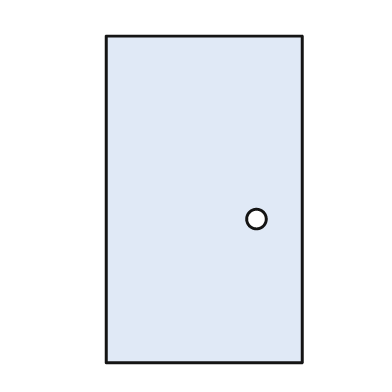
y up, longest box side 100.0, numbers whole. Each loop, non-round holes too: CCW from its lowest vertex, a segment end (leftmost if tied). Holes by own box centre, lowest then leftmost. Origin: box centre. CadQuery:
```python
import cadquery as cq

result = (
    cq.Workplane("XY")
    .moveTo(-30.0, -50.0)
    .lineTo(30.0, -50.0)
    .lineTo(30.0, 50.0)
    .lineTo(-30.0, 50.0)
    .close()
    .moveTo(16.0, -6.0)
    .circle(3.0)
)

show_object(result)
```